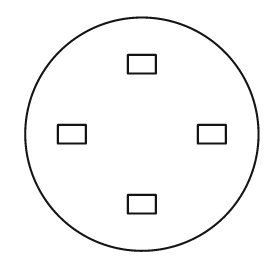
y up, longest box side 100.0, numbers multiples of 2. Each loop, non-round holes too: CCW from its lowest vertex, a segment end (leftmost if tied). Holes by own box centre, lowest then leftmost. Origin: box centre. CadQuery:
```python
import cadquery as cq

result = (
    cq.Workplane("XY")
    .moveTo(0.0, 0.0)
    .circle(50.0)
    .moveTo(-6.0, -34.0)
    .lineTo(6.0, -34.0)
    .lineTo(6.0, -26.0)
    .lineTo(-6.0, -26.0)
    .close()
    .moveTo(-36.0, -4.0)
    .lineTo(-24.0, -4.0)
    .lineTo(-24.0, 4.0)
    .lineTo(-36.0, 4.0)
    .close()
    .moveTo(24.0, -4.0)
    .lineTo(36.0, -4.0)
    .lineTo(36.0, 4.0)
    .lineTo(24.0, 4.0)
    .close()
    .moveTo(-6.0, 26.0)
    .lineTo(6.0, 26.0)
    .lineTo(6.0, 34.0)
    .lineTo(-6.0, 34.0)
    .close()
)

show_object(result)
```